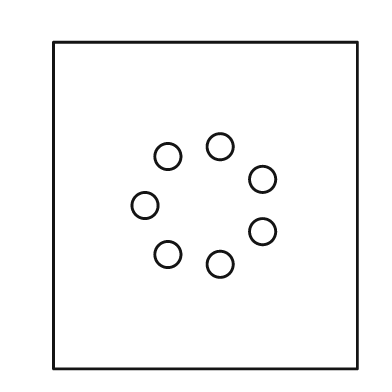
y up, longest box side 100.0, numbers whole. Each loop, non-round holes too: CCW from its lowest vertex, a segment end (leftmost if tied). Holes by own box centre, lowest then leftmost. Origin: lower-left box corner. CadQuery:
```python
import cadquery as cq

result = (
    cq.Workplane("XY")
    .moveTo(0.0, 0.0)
    .lineTo(93.0, 0.0)
    .lineTo(93.0, 100.0)
    .lineTo(0.0, 100.0)
    .close()
    .moveTo(51.0, 32.0)
    .circle(4.0)
    .moveTo(35.0, 35.0)
    .circle(4.0)
    .moveTo(64.0, 42.0)
    .circle(4.0)
    .moveTo(28.0, 50.0)
    .circle(4.0)
    .moveTo(64.0, 58.0)
    .circle(4.0)
    .moveTo(35.0, 65.0)
    .circle(4.0)
    .moveTo(51.0, 68.0)
    .circle(4.0)
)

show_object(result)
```